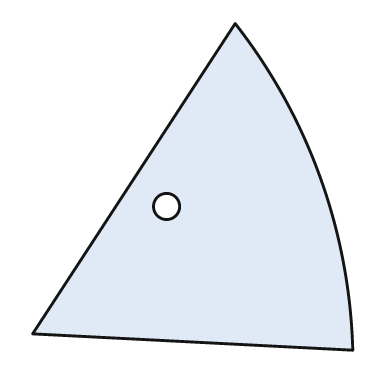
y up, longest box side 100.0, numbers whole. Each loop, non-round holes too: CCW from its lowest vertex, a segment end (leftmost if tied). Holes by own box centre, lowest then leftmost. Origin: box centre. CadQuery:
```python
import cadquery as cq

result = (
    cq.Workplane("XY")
    .moveTo(49.0, -50.0)
    .threePointArc((39.0, 3.0), (13.0, 50.0))
    .lineTo(-49.0, -45.0)
    .close()
    .moveTo(-8.0, -6.0)
    .circle(4.0)
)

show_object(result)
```